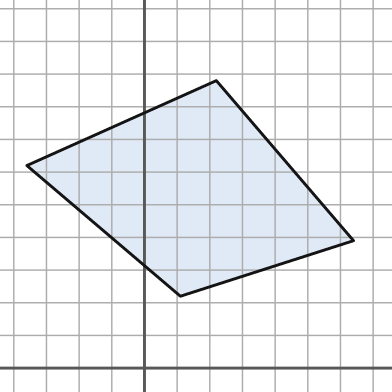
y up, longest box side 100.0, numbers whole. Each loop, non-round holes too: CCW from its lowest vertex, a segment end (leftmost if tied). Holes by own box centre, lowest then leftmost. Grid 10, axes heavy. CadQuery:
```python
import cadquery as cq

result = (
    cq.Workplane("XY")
    .moveTo(11.0, 22.0)
    .lineTo(64.0, 39.0)
    .lineTo(22.0, 88.0)
    .lineTo(-36.0, 62.0)
    .close()
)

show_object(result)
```